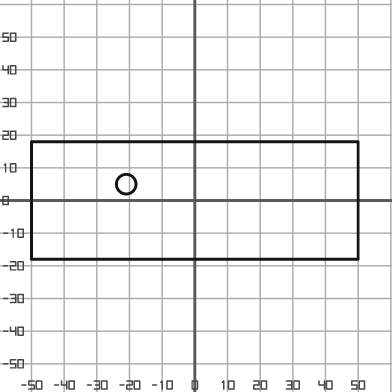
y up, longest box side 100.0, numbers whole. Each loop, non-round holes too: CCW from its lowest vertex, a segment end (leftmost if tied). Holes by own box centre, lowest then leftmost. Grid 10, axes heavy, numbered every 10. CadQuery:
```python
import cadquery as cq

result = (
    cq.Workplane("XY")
    .moveTo(-50.0, -18.0)
    .lineTo(50.0, -18.0)
    .lineTo(50.0, 18.0)
    .lineTo(-50.0, 18.0)
    .close()
    .moveTo(-21.0, 5.0)
    .circle(3.0)
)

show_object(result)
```